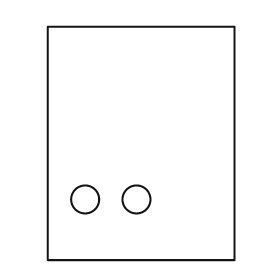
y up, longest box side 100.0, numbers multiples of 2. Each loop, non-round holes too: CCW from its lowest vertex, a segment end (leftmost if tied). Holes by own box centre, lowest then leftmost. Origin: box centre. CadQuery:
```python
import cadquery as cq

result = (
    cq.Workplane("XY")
    .moveTo(-40.0, -50.0)
    .lineTo(40.0, -50.0)
    .lineTo(40.0, 50.0)
    .lineTo(-40.0, 50.0)
    .close()
    .moveTo(-24.0, -24.0)
    .circle(6.0)
    .moveTo(-2.0, -24.0)
    .circle(6.0)
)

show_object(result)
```